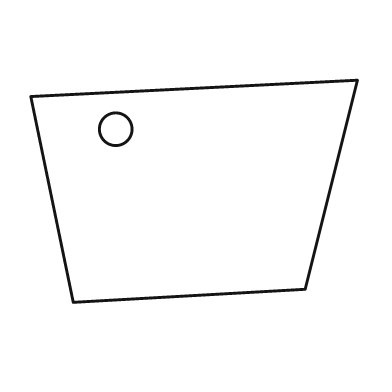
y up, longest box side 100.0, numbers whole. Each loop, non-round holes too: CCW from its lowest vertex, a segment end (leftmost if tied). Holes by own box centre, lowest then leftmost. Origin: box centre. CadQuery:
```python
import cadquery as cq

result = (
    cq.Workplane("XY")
    .moveTo(-37.0, -34.0)
    .lineTo(34.0, -30.0)
    .lineTo(50.0, 34.0)
    .lineTo(-50.0, 29.0)
    .close()
    .moveTo(-24.0, 19.0)
    .circle(5.0)
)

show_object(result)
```